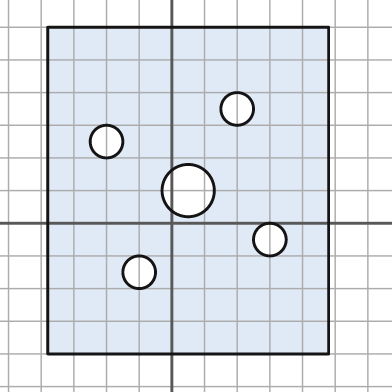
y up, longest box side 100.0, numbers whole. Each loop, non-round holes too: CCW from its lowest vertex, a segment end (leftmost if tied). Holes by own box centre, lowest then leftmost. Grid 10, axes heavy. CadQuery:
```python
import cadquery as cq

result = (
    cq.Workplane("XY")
    .moveTo(-38.0, -40.0)
    .lineTo(48.0, -40.0)
    .lineTo(48.0, 60.0)
    .lineTo(-38.0, 60.0)
    .close()
    .moveTo(-10.0, -15.0)
    .circle(5.0)
    .moveTo(30.0, -5.0)
    .circle(5.0)
    .moveTo(5.0, 10.0)
    .circle(8.0)
    .moveTo(-20.0, 25.0)
    .circle(5.0)
    .moveTo(20.0, 35.0)
    .circle(5.0)
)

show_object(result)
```